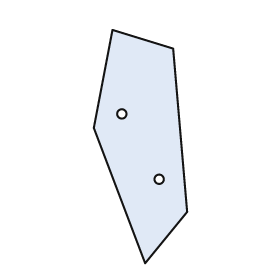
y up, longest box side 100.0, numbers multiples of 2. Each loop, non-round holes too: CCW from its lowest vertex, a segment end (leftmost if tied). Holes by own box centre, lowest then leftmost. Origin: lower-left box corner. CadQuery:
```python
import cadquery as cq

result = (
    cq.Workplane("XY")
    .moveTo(22.0, 0.0)
    .lineTo(40.0, 22.0)
    .lineTo(34.0, 92.0)
    .lineTo(8.0, 100.0)
    .lineTo(0.0, 58.0)
    .close()
    .moveTo(28.0, 36.0)
    .circle(2.0)
    .moveTo(12.0, 64.0)
    .circle(2.0)
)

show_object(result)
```